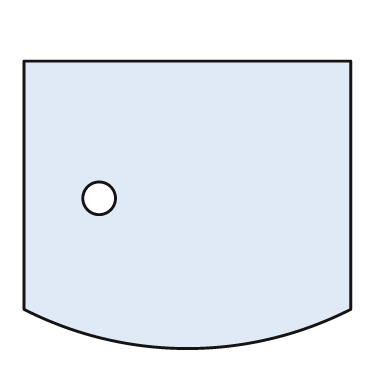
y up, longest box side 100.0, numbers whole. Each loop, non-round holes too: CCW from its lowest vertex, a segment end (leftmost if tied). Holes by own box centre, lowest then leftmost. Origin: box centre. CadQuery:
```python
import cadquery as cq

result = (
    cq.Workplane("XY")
    .moveTo(-50.0, -32.0)
    .threePointArc((0.0, -44.0), (50.0, -32.0))
    .lineTo(50.0, 44.0)
    .lineTo(-50.0, 44.0)
    .close()
    .moveTo(-27.0, 2.0)
    .circle(5.0)
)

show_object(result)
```